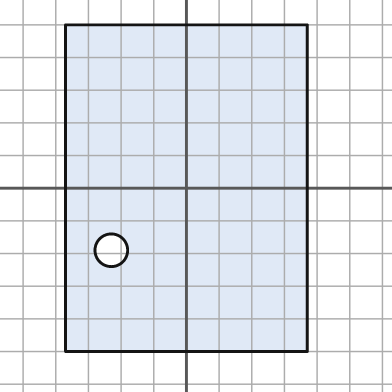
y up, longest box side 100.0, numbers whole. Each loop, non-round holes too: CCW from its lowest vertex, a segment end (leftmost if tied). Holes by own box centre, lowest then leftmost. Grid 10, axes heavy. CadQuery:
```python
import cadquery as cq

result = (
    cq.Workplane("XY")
    .moveTo(-37.0, -50.0)
    .lineTo(37.0, -50.0)
    .lineTo(37.0, 50.0)
    .lineTo(-37.0, 50.0)
    .close()
    .moveTo(-23.0, -19.0)
    .circle(5.0)
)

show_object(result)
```